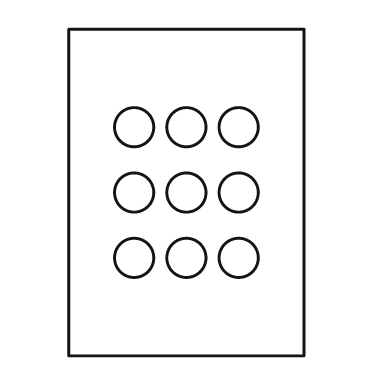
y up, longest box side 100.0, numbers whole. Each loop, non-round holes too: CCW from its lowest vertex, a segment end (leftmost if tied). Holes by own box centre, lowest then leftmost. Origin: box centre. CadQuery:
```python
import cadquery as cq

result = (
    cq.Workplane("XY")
    .moveTo(-36.0, -50.0)
    .lineTo(36.0, -50.0)
    .lineTo(36.0, 50.0)
    .lineTo(-36.0, 50.0)
    .close()
    .moveTo(-16.0, -20.0)
    .circle(6.0)
    .moveTo(0.0, -20.0)
    .circle(6.0)
    .moveTo(16.0, -20.0)
    .circle(6.0)
    .moveTo(-16.0, 0.0)
    .circle(6.0)
    .moveTo(0.0, 0.0)
    .circle(6.0)
    .moveTo(16.0, 0.0)
    .circle(6.0)
    .moveTo(-16.0, 20.0)
    .circle(6.0)
    .moveTo(0.0, 20.0)
    .circle(6.0)
    .moveTo(16.0, 20.0)
    .circle(6.0)
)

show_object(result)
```